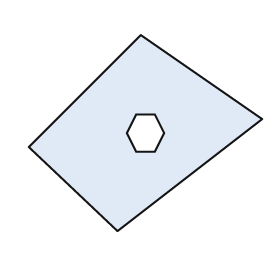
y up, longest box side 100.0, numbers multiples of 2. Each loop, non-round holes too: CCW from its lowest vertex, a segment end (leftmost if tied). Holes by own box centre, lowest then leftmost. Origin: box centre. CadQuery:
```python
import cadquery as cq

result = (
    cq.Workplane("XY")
    .moveTo(-12.0, -42.0)
    .lineTo(50.0, 6.0)
    .lineTo(-2.0, 42.0)
    .lineTo(-50.0, -6.0)
    .close()
    .moveTo(-4.0, -8.0)
    .lineTo(4.0, -8.0)
    .lineTo(8.0, 0.0)
    .lineTo(4.0, 8.0)
    .lineTo(-4.0, 8.0)
    .lineTo(-8.0, 0.0)
    .close()
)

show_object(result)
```